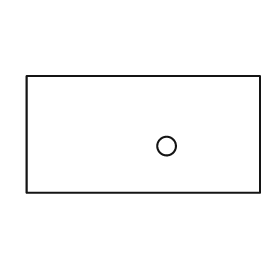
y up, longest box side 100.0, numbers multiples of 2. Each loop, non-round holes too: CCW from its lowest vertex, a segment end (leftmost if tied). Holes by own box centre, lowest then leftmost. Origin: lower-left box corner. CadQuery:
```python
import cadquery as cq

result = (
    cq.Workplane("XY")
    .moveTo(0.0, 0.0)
    .lineTo(100.0, 0.0)
    .lineTo(100.0, 50.0)
    .lineTo(0.0, 50.0)
    .close()
    .moveTo(60.0, 20.0)
    .circle(4.0)
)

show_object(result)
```